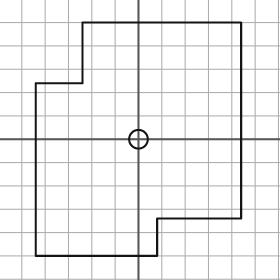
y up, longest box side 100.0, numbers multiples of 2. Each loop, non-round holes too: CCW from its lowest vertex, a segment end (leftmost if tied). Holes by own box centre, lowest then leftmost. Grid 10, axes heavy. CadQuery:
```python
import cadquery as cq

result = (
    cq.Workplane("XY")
    .moveTo(-44.0, -50.0)
    .lineTo(8.0, -50.0)
    .lineTo(8.0, -34.0)
    .lineTo(44.0, -34.0)
    .lineTo(44.0, 50.0)
    .lineTo(-24.0, 50.0)
    .lineTo(-24.0, 24.0)
    .lineTo(-44.0, 24.0)
    .close()
    .moveTo(0.0, 0.0)
    .circle(4.0)
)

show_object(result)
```